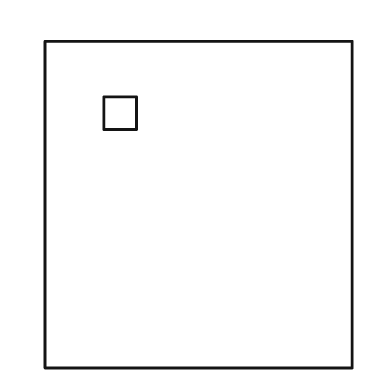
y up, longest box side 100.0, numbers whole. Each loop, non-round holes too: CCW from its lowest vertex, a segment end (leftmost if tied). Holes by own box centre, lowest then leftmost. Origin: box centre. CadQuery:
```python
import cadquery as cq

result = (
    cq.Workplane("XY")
    .moveTo(-47.0, -50.0)
    .lineTo(47.0, -50.0)
    .lineTo(47.0, 50.0)
    .lineTo(-47.0, 50.0)
    .close()
    .moveTo(-29.0, 23.0)
    .lineTo(-19.0, 23.0)
    .lineTo(-19.0, 33.0)
    .lineTo(-29.0, 33.0)
    .close()
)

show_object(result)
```